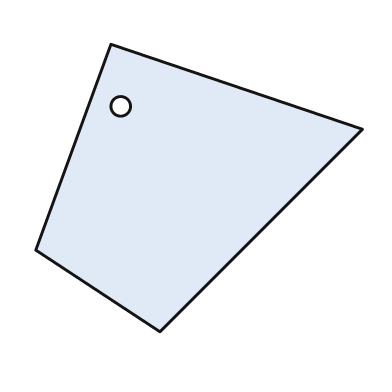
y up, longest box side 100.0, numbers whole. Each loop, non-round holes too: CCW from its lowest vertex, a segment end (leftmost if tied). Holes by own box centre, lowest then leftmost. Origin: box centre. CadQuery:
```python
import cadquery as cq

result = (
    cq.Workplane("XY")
    .moveTo(-12.0, -44.0)
    .lineTo(50.0, 18.0)
    .lineTo(-27.0, 44.0)
    .lineTo(-50.0, -19.0)
    .close()
    .moveTo(-24.0, 25.0)
    .circle(3.0)
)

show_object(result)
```